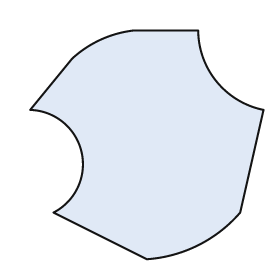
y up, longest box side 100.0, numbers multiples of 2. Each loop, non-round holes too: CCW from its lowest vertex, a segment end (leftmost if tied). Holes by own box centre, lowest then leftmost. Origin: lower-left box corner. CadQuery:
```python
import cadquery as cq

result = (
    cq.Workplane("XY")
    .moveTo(50.0, 0.0)
    .threePointArc((72.0, 6.0), (90.0, 20.0))
    .lineTo(100.0, 64.0)
    .threePointArc((80.0, 76.0), (72.0, 98.0))
    .lineTo(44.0, 98.0)
    .threePointArc((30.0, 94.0), (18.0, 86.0))
    .lineTo(0.0, 64.0)
    .threePointArc((22.0, 46.0), (10.0, 20.0))
    .close()
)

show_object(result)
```